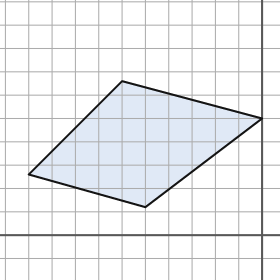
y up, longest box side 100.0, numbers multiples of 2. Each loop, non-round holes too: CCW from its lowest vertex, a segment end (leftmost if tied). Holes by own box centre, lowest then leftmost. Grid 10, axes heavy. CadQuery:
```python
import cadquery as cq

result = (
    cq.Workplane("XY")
    .moveTo(-50.0, 12.0)
    .lineTo(0.0, 50.0)
    .lineTo(-60.0, 66.0)
    .lineTo(-100.0, 26.0)
    .close()
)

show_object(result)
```